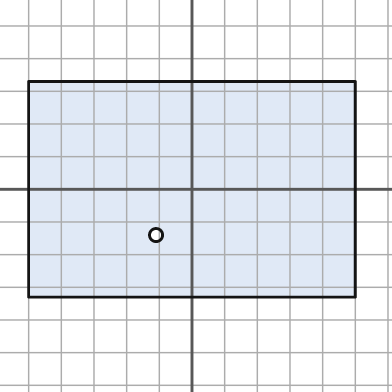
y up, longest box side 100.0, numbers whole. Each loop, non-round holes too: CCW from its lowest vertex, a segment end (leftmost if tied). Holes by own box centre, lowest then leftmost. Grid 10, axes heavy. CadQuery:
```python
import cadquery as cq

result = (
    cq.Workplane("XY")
    .moveTo(-50.0, -33.0)
    .lineTo(50.0, -33.0)
    .lineTo(50.0, 33.0)
    .lineTo(-50.0, 33.0)
    .close()
    .moveTo(-11.0, -14.0)
    .circle(2.0)
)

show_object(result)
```